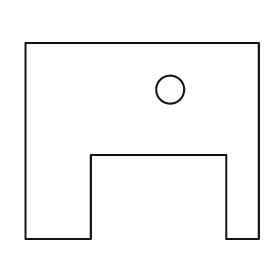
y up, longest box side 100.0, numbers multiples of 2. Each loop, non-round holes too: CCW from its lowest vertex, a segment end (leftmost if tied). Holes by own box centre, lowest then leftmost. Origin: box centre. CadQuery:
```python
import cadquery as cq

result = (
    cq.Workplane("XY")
    .moveTo(-50.0, -42.0)
    .lineTo(-22.0, -42.0)
    .lineTo(-22.0, -6.0)
    .lineTo(36.0, -6.0)
    .lineTo(36.0, -42.0)
    .lineTo(50.0, -42.0)
    .lineTo(50.0, 42.0)
    .lineTo(-50.0, 42.0)
    .close()
    .moveTo(12.0, 22.0)
    .circle(6.0)
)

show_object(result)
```